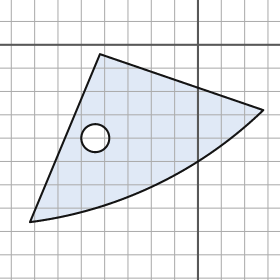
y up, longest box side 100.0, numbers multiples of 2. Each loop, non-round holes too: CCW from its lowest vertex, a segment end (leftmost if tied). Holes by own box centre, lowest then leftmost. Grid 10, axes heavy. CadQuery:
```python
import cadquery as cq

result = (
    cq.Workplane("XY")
    .moveTo(-72.0, -76.0)
    .threePointArc((-18.0, -60.0), (28.0, -28.0))
    .lineTo(-42.0, -4.0)
    .close()
    .moveTo(-44.0, -40.0)
    .circle(6.0)
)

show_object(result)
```